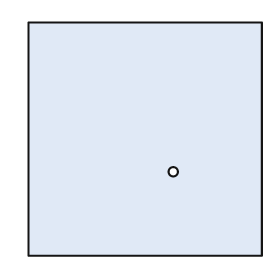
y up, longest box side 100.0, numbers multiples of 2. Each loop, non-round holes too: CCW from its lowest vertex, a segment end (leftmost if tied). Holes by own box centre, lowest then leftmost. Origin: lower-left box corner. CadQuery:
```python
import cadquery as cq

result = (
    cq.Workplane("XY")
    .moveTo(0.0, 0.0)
    .lineTo(100.0, 0.0)
    .lineTo(100.0, 100.0)
    .lineTo(0.0, 100.0)
    .close()
    .moveTo(62.0, 36.0)
    .circle(2.0)
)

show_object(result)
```